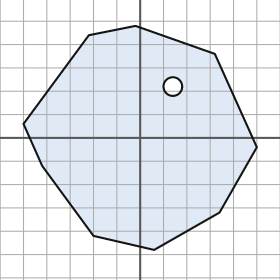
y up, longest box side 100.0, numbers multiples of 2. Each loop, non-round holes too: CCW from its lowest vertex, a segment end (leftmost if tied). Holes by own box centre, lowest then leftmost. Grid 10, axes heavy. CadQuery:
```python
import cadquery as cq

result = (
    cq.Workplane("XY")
    .moveTo(6.0, -48.0)
    .lineTo(34.0, -32.0)
    .lineTo(50.0, -4.0)
    .lineTo(32.0, 36.0)
    .lineTo(-2.0, 48.0)
    .lineTo(-22.0, 44.0)
    .lineTo(-50.0, 6.0)
    .lineTo(-42.0, -12.0)
    .lineTo(-20.0, -42.0)
    .close()
    .moveTo(14.0, 22.0)
    .circle(4.0)
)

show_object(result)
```